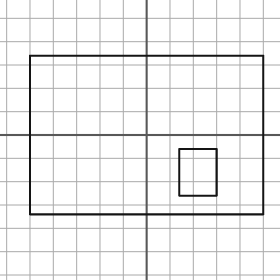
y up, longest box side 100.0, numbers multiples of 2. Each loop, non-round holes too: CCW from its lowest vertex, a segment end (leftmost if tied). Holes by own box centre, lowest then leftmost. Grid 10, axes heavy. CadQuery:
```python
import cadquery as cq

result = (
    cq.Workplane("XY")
    .moveTo(-50.0, -34.0)
    .lineTo(50.0, -34.0)
    .lineTo(50.0, 34.0)
    .lineTo(-50.0, 34.0)
    .close()
    .moveTo(14.0, -26.0)
    .lineTo(30.0, -26.0)
    .lineTo(30.0, -6.0)
    .lineTo(14.0, -6.0)
    .close()
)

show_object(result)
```